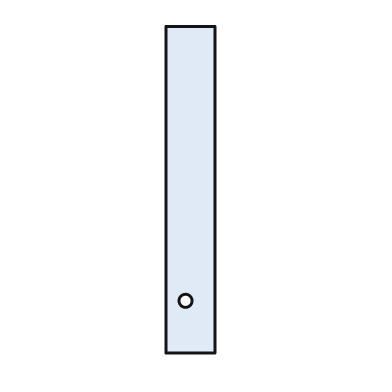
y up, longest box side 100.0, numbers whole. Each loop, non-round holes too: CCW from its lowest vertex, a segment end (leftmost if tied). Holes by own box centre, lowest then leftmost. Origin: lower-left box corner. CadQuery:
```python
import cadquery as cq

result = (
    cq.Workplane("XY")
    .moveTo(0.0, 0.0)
    .lineTo(15.0, 0.0)
    .lineTo(15.0, 100.0)
    .lineTo(0.0, 100.0)
    .close()
    .moveTo(6.0, 16.0)
    .circle(2.0)
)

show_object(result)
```